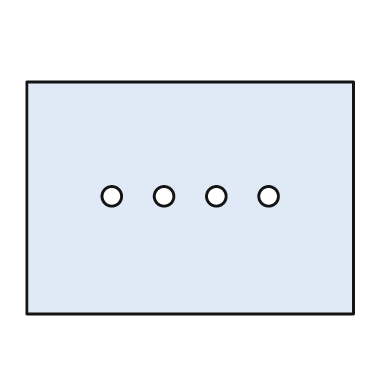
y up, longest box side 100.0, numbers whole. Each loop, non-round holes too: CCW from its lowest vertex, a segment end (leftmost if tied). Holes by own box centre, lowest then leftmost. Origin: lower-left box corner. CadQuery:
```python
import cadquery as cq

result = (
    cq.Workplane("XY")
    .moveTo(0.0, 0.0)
    .lineTo(100.0, 0.0)
    .lineTo(100.0, 71.0)
    .lineTo(0.0, 71.0)
    .close()
    .moveTo(26.0, 36.0)
    .circle(3.0)
    .moveTo(42.0, 36.0)
    .circle(3.0)
    .moveTo(58.0, 36.0)
    .circle(3.0)
    .moveTo(74.0, 36.0)
    .circle(3.0)
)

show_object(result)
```